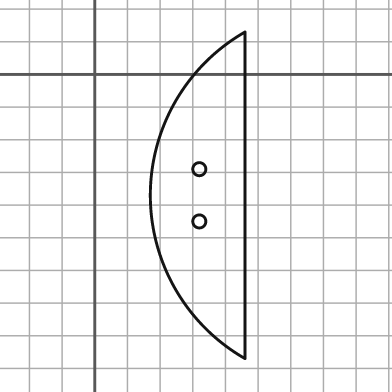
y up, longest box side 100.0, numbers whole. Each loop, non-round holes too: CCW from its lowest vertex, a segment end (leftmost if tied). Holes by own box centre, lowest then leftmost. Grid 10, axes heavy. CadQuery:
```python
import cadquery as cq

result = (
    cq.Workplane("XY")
    .moveTo(46.0, -87.0)
    .lineTo(46.0, 13.0)
    .threePointArc((17.0, -37.0), (46.0, -87.0))
    .close()
    .moveTo(32.0, -45.0)
    .circle(2.0)
    .moveTo(32.0, -29.0)
    .circle(2.0)
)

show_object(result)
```